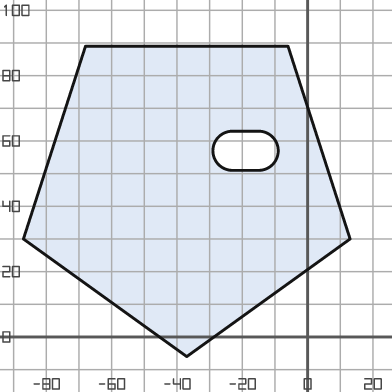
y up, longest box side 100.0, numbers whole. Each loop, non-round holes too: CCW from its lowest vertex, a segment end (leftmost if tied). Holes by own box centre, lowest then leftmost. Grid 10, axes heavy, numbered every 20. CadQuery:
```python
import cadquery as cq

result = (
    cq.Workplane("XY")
    .moveTo(-37.0, -6.0)
    .lineTo(13.0, 30.0)
    .lineTo(-6.0, 89.0)
    .lineTo(-68.0, 89.0)
    .lineTo(-87.0, 30.0)
    .close()
    .moveTo(-23.0, 51.0)
    .lineTo(-15.0, 51.0)
    .threePointArc((-9.0, 57.0), (-15.0, 63.0))
    .lineTo(-23.0, 63.0)
    .threePointArc((-29.0, 57.0), (-23.0, 51.0))
    .close()
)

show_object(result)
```